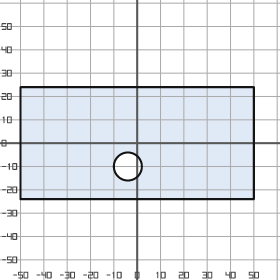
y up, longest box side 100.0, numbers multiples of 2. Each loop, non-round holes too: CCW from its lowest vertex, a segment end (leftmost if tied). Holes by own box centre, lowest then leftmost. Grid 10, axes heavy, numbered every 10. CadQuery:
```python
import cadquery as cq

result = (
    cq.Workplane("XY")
    .moveTo(-50.0, -24.0)
    .lineTo(50.0, -24.0)
    .lineTo(50.0, 24.0)
    .lineTo(-50.0, 24.0)
    .close()
    .moveTo(-4.0, -10.0)
    .circle(6.0)
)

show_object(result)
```